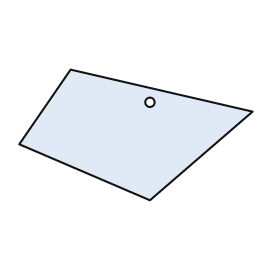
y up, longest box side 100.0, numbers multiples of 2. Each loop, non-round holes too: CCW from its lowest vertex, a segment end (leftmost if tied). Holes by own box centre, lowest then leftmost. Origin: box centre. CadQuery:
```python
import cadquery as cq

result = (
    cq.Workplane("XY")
    .moveTo(6.0, -28.0)
    .lineTo(50.0, 10.0)
    .lineTo(-28.0, 28.0)
    .lineTo(-50.0, -4.0)
    .close()
    .moveTo(6.0, 14.0)
    .circle(2.0)
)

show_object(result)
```